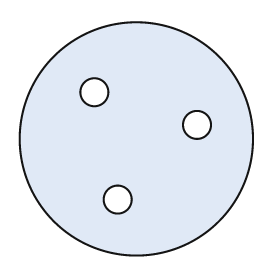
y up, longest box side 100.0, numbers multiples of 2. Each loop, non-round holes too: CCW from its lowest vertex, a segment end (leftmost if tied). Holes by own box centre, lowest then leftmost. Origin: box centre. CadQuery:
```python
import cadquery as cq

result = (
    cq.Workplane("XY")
    .moveTo(0.0, 0.0)
    .circle(50.0)
    .moveTo(-8.0, -26.0)
    .circle(6.0)
    .moveTo(26.0, 6.0)
    .circle(6.0)
    .moveTo(-18.0, 20.0)
    .circle(6.0)
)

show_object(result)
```